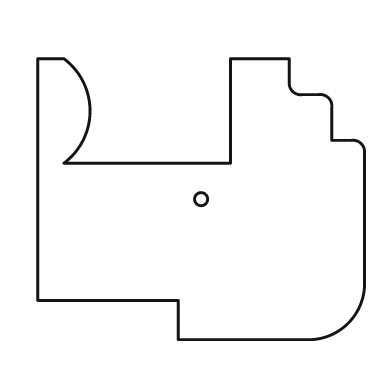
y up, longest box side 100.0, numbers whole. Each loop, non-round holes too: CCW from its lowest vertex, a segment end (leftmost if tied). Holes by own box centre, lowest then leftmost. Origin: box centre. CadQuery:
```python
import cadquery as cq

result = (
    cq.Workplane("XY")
    .moveTo(-7.0, -43.0)
    .lineTo(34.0, -43.0)
    .threePointArc((45.0, -38.0), (50.0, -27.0))
    .lineTo(50.0, 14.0)
    .threePointArc((49.0, 17.0), (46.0, 18.0))
    .lineTo(40.0, 18.0)
    .lineTo(40.0, 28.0)
    .threePointArc((39.0, 31.0), (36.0, 32.0))
    .lineTo(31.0, 32.0)
    .threePointArc((28.0, 33.0), (27.0, 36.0))
    .lineTo(27.0, 43.0)
    .lineTo(9.0, 43.0)
    .lineTo(9.0, 11.0)
    .lineTo(-42.0, 11.0)
    .threePointArc((-34.0, 27.0), (-42.0, 43.0))
    .lineTo(-50.0, 43.0)
    .lineTo(-50.0, -31.0)
    .lineTo(-7.0, -31.0)
    .close()
    .moveTo(0.0, 0.0)
    .circle(2.0)
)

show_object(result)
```